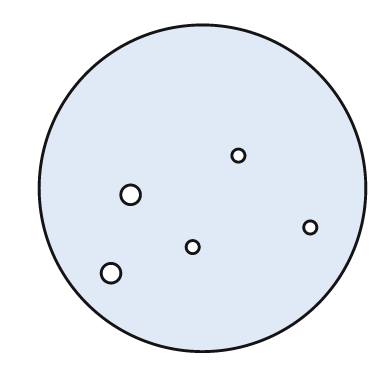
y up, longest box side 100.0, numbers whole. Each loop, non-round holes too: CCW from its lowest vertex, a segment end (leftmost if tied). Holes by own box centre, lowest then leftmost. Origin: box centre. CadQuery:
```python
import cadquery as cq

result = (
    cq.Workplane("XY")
    .moveTo(0.0, 0.0)
    .circle(50.0)
    .moveTo(-28.0, -26.0)
    .circle(3.0)
    .moveTo(-3.0, -18.0)
    .circle(2.0)
    .moveTo(33.0, -12.0)
    .circle(2.0)
    .moveTo(-22.0, -2.0)
    .circle(3.0)
    .moveTo(11.0, 10.0)
    .circle(2.0)
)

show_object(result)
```